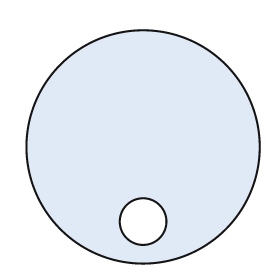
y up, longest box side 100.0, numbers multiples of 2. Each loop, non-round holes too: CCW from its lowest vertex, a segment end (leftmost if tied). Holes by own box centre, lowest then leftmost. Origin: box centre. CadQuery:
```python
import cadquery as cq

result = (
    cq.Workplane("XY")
    .moveTo(0.0, 0.0)
    .circle(50.0)
    .moveTo(0.0, -32.0)
    .circle(10.0)
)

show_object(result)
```